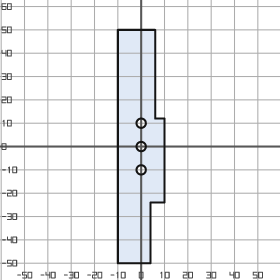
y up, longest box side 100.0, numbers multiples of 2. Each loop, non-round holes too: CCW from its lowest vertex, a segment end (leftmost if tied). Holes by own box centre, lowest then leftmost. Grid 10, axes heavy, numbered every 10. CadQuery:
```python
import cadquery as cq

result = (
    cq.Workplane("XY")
    .moveTo(-10.0, -50.0)
    .lineTo(4.0, -50.0)
    .lineTo(4.0, -24.0)
    .lineTo(10.0, -24.0)
    .lineTo(10.0, 12.0)
    .lineTo(6.0, 12.0)
    .lineTo(6.0, 50.0)
    .lineTo(-10.0, 50.0)
    .close()
    .moveTo(0.0, -10.0)
    .circle(2.0)
    .moveTo(0.0, 0.0)
    .circle(2.0)
    .moveTo(0.0, 10.0)
    .circle(2.0)
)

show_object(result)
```